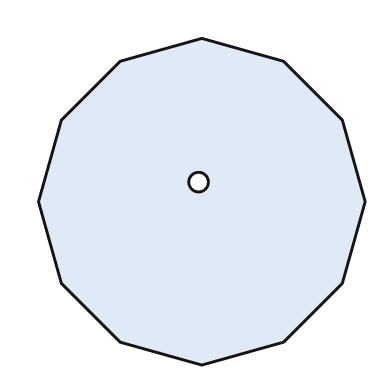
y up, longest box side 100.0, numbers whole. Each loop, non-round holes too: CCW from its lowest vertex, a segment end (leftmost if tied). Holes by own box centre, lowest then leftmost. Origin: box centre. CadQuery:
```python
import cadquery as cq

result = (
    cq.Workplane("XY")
    .moveTo(0.0, -50.0)
    .lineTo(25.0, -43.0)
    .lineTo(43.0, -25.0)
    .lineTo(50.0, 0.0)
    .lineTo(43.0, 25.0)
    .lineTo(25.0, 43.0)
    .lineTo(0.0, 50.0)
    .lineTo(-25.0, 43.0)
    .lineTo(-43.0, 25.0)
    .lineTo(-50.0, 0.0)
    .lineTo(-43.0, -25.0)
    .lineTo(-25.0, -43.0)
    .close()
    .moveTo(-1.0, 6.0)
    .circle(3.0)
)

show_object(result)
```